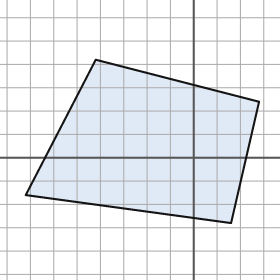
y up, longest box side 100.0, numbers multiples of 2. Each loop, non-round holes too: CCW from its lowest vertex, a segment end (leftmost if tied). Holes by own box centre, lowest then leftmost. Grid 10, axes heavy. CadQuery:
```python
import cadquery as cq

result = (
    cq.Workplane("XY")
    .moveTo(16.0, -28.0)
    .lineTo(28.0, 24.0)
    .lineTo(-42.0, 42.0)
    .lineTo(-72.0, -16.0)
    .close()
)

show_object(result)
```